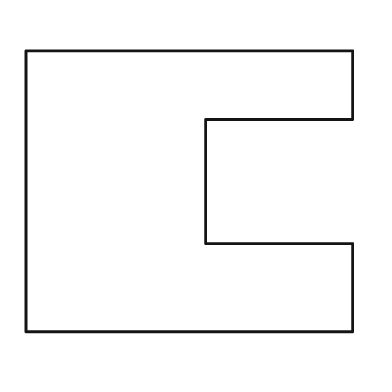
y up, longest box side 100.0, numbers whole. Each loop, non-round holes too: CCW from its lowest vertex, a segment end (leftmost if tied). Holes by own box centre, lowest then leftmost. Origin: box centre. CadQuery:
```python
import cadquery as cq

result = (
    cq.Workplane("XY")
    .moveTo(-50.0, -43.0)
    .lineTo(50.0, -43.0)
    .lineTo(50.0, -16.0)
    .lineTo(5.0, -16.0)
    .lineTo(5.0, 22.0)
    .lineTo(50.0, 22.0)
    .lineTo(50.0, 43.0)
    .lineTo(-50.0, 43.0)
    .close()
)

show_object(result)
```